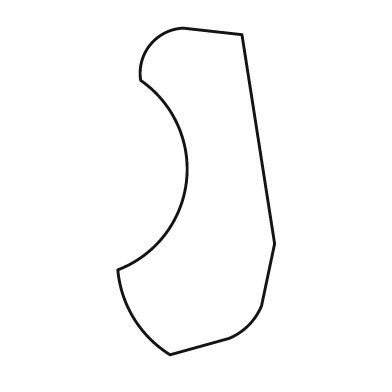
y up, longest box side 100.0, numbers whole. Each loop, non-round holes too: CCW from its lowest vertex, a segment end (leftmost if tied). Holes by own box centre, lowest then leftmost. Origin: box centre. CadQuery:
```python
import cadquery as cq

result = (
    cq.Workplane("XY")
    .moveTo(-8.0, -50.0)
    .lineTo(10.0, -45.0)
    .threePointArc((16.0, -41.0), (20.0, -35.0))
    .lineTo(24.0, -16.0)
    .lineTo(14.0, 48.0)
    .lineTo(-4.0, 50.0)
    .threePointArc((-14.0, 45.0), (-17.0, 34.0))
    .threePointArc((-3.0, 3.0), (-24.0, -24.0))
    .threePointArc((-19.0, -39.0), (-8.0, -50.0))
    .close()
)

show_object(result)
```